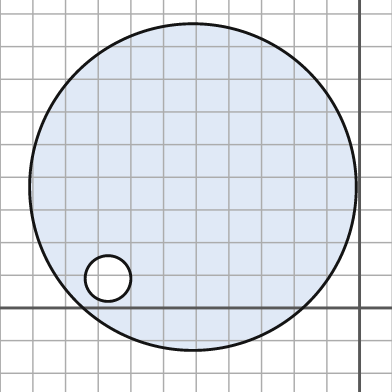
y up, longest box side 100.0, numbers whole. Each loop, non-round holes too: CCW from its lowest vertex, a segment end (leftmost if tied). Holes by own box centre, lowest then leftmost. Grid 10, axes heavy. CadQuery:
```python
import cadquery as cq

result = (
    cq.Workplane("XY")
    .moveTo(-51.0, 37.0)
    .circle(50.0)
    .moveTo(-77.0, 9.0)
    .circle(7.0)
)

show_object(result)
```